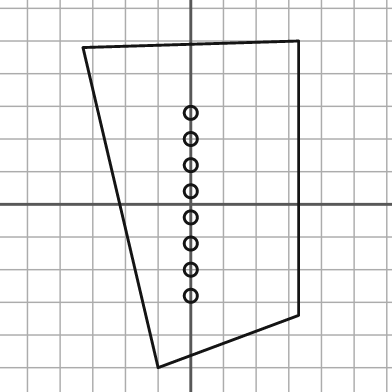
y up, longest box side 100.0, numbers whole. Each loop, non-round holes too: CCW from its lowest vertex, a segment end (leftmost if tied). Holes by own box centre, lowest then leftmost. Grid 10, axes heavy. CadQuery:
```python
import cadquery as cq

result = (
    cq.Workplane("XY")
    .moveTo(-10.0, -50.0)
    .lineTo(33.0, -34.0)
    .lineTo(33.0, 50.0)
    .lineTo(-33.0, 48.0)
    .close()
    .moveTo(0.0, -28.0)
    .circle(2.0)
    .moveTo(0.0, -20.0)
    .circle(2.0)
    .moveTo(0.0, -12.0)
    .circle(2.0)
    .moveTo(0.0, -4.0)
    .circle(2.0)
    .moveTo(0.0, 4.0)
    .circle(2.0)
    .moveTo(0.0, 12.0)
    .circle(2.0)
    .moveTo(0.0, 20.0)
    .circle(2.0)
    .moveTo(0.0, 28.0)
    .circle(2.0)
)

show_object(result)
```